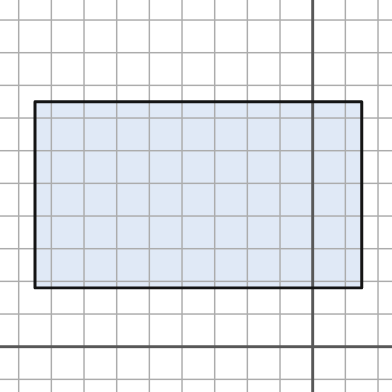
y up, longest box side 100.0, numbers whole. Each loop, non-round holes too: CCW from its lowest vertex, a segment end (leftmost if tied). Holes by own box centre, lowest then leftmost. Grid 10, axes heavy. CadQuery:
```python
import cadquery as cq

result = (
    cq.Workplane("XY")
    .moveTo(-85.0, 18.0)
    .lineTo(15.0, 18.0)
    .lineTo(15.0, 75.0)
    .lineTo(-85.0, 75.0)
    .close()
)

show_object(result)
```